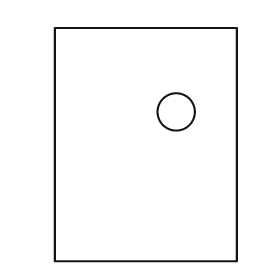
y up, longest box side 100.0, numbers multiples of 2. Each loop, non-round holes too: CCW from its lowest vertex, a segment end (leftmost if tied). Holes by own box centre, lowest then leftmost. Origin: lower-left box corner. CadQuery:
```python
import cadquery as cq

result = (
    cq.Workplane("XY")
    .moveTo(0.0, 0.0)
    .lineTo(78.0, 0.0)
    .lineTo(78.0, 100.0)
    .lineTo(0.0, 100.0)
    .close()
    .moveTo(52.0, 64.0)
    .circle(8.0)
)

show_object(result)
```